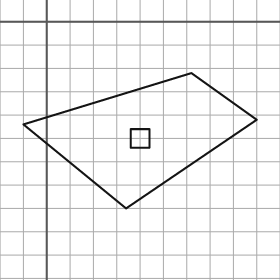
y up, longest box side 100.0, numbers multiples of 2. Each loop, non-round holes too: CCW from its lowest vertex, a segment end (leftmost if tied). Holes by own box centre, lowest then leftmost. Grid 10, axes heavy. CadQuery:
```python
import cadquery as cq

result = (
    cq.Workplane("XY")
    .moveTo(34.0, -80.0)
    .lineTo(90.0, -42.0)
    .lineTo(62.0, -22.0)
    .lineTo(-10.0, -44.0)
    .close()
    .moveTo(36.0, -54.0)
    .lineTo(44.0, -54.0)
    .lineTo(44.0, -46.0)
    .lineTo(36.0, -46.0)
    .close()
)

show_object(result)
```